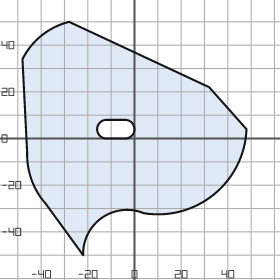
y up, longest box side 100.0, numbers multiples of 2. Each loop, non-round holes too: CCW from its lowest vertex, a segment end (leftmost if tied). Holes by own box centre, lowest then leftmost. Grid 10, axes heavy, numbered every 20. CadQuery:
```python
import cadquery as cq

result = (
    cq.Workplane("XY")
    .moveTo(-22.0, -50.0)
    .threePointArc((-14.0, -34.0), (4.0, -32.0))
    .threePointArc((34.0, -24.0), (48.0, 4.0))
    .lineTo(32.0, 22.0)
    .lineTo(-28.0, 50.0)
    .threePointArc((-40.0, 44.0), (-48.0, 34.0))
    .lineTo(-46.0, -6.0)
    .threePointArc((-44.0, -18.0), (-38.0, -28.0))
    .close()
    .moveTo(-12.0, 0.0)
    .lineTo(-4.0, 0.0)
    .threePointArc((0.0, 4.0), (-4.0, 8.0))
    .lineTo(-12.0, 8.0)
    .threePointArc((-16.0, 4.0), (-12.0, 0.0))
    .close()
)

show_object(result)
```